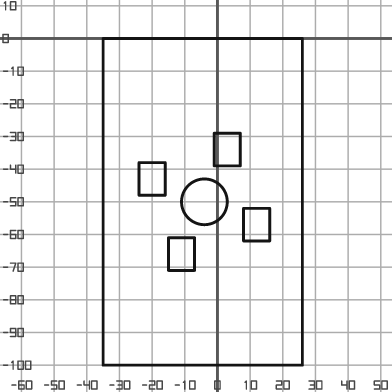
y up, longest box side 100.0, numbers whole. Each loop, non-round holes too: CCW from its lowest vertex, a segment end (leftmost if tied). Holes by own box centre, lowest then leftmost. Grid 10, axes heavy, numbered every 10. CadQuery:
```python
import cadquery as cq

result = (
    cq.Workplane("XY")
    .moveTo(-35.0, -100.0)
    .lineTo(26.0, -100.0)
    .lineTo(26.0, 0.0)
    .lineTo(-35.0, 0.0)
    .close()
    .moveTo(-15.0, -71.0)
    .lineTo(-7.0, -71.0)
    .lineTo(-7.0, -61.0)
    .lineTo(-15.0, -61.0)
    .close()
    .moveTo(8.0, -62.0)
    .lineTo(16.0, -62.0)
    .lineTo(16.0, -52.0)
    .lineTo(8.0, -52.0)
    .close()
    .moveTo(-4.0, -50.0)
    .circle(7.0)
    .moveTo(-24.0, -48.0)
    .lineTo(-16.0, -48.0)
    .lineTo(-16.0, -38.0)
    .lineTo(-24.0, -38.0)
    .close()
    .moveTo(-1.0, -39.0)
    .lineTo(7.0, -39.0)
    .lineTo(7.0, -29.0)
    .lineTo(-1.0, -29.0)
    .close()
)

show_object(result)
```